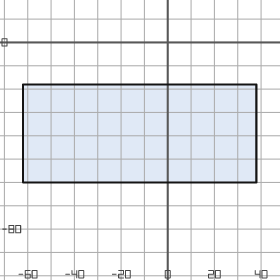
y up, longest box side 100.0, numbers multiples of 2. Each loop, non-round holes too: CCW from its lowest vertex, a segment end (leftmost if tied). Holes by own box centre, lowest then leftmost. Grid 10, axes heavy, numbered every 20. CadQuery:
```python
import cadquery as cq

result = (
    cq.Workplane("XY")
    .moveTo(-62.0, -60.0)
    .lineTo(38.0, -60.0)
    .lineTo(38.0, -18.0)
    .lineTo(-62.0, -18.0)
    .close()
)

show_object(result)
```